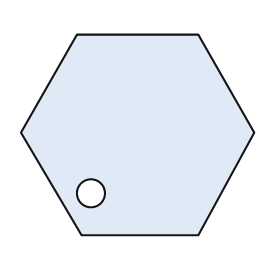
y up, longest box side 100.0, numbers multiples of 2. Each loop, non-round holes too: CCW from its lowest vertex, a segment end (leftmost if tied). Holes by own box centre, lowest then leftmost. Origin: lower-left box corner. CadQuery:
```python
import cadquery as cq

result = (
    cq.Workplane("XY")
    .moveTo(26.0, 0.0)
    .lineTo(76.0, 0.0)
    .lineTo(100.0, 44.0)
    .lineTo(76.0, 86.0)
    .lineTo(24.0, 86.0)
    .lineTo(0.0, 44.0)
    .close()
    .moveTo(30.0, 18.0)
    .circle(6.0)
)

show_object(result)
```